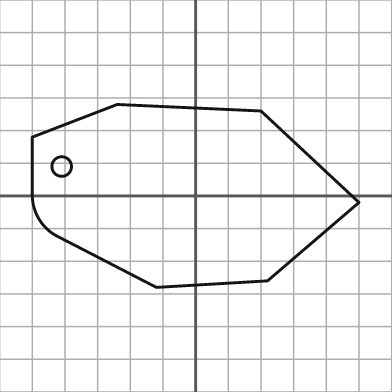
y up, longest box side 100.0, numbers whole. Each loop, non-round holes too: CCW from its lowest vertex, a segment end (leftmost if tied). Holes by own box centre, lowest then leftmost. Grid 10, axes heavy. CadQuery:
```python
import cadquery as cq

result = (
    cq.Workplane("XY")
    .moveTo(-12.0, -28.0)
    .lineTo(22.0, -26.0)
    .lineTo(50.0, -2.0)
    .lineTo(20.0, 26.0)
    .lineTo(-24.0, 28.0)
    .lineTo(-50.0, 18.0)
    .lineTo(-50.0, 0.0)
    .threePointArc((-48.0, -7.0), (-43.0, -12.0))
    .close()
    .moveTo(-41.0, 9.0)
    .circle(3.0)
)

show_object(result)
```